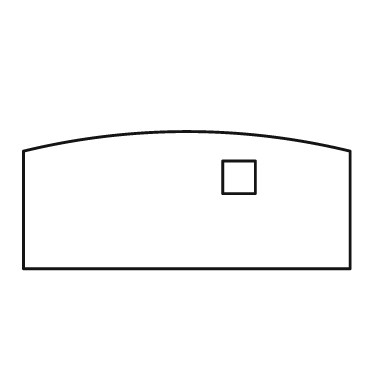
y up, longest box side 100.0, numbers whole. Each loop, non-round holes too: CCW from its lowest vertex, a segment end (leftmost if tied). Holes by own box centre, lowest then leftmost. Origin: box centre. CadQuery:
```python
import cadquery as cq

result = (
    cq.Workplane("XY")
    .moveTo(-50.0, -21.0)
    .lineTo(50.0, -21.0)
    .lineTo(50.0, 15.0)
    .threePointArc((0.0, 21.0), (-50.0, 15.0))
    .close()
    .moveTo(11.0, 2.0)
    .lineTo(21.0, 2.0)
    .lineTo(21.0, 12.0)
    .lineTo(11.0, 12.0)
    .close()
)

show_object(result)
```